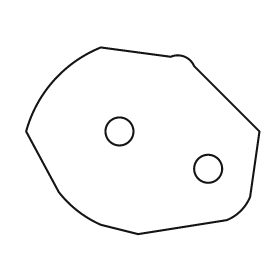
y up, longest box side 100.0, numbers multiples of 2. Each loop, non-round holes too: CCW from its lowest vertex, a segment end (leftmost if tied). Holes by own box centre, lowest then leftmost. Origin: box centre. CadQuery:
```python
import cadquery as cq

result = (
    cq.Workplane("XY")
    .moveTo(-2.0, -40.0)
    .lineTo(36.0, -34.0)
    .threePointArc((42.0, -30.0), (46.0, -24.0))
    .lineTo(50.0, 4.0)
    .lineTo(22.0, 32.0)
    .threePointArc((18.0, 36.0), (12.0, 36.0))
    .lineTo(-18.0, 40.0)
    .threePointArc((-38.0, 26.0), (-50.0, 4.0))
    .lineTo(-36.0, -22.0)
    .threePointArc((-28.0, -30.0), (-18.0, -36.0))
    .close()
    .moveTo(28.0, -12.0)
    .circle(6.0)
    .moveTo(-10.0, 4.0)
    .circle(6.0)
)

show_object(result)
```